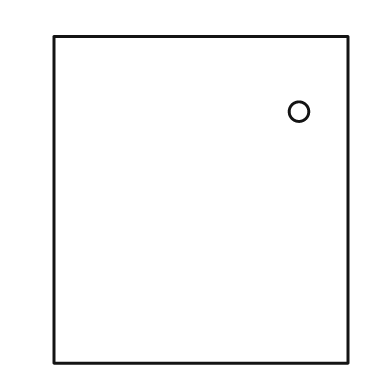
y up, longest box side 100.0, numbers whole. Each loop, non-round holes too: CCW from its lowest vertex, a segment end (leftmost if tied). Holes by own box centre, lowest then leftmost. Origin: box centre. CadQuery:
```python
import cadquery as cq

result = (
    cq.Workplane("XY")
    .moveTo(-45.0, -50.0)
    .lineTo(45.0, -50.0)
    .lineTo(45.0, 50.0)
    .lineTo(-45.0, 50.0)
    .close()
    .moveTo(30.0, 27.0)
    .circle(3.0)
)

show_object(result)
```